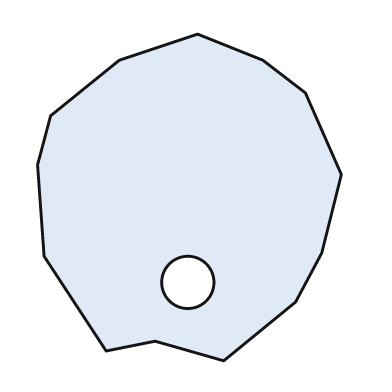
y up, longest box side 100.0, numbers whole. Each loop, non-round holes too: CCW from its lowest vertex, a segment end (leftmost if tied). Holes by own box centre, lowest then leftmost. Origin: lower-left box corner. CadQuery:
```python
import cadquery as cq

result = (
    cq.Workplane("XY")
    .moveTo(57.0, 0.0)
    .lineTo(79.0, 18.0)
    .lineTo(87.0, 33.0)
    .lineTo(93.0, 57.0)
    .lineTo(82.0, 82.0)
    .lineTo(69.0, 92.0)
    .lineTo(49.0, 100.0)
    .lineTo(25.0, 92.0)
    .lineTo(4.0, 75.0)
    .lineTo(0.0, 60.0)
    .lineTo(2.0, 32.0)
    .lineTo(21.0, 3.0)
    .lineTo(36.0, 6.0)
    .close()
    .moveTo(46.0, 24.0)
    .circle(8.0)
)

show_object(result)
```